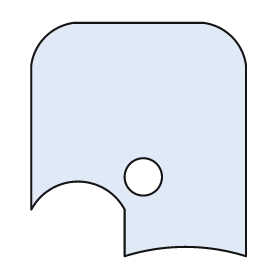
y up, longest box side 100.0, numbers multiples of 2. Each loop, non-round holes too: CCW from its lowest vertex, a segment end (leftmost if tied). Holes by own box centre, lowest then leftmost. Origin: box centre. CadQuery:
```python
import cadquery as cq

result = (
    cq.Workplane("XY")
    .moveTo(-6.0, -50.0)
    .threePointArc((20.0, -46.0), (46.0, -50.0))
    .lineTo(46.0, 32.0)
    .threePointArc((40.0, 44.0), (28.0, 50.0))
    .lineTo(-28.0, 50.0)
    .threePointArc((-40.0, 44.0), (-46.0, 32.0))
    .lineTo(-46.0, -30.0)
    .threePointArc((-26.0, -18.0), (-6.0, -30.0))
    .close()
    .moveTo(2.0, -16.0)
    .circle(8.0)
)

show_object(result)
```